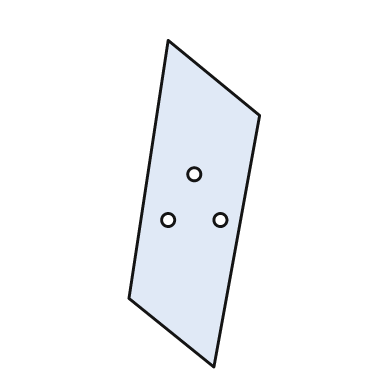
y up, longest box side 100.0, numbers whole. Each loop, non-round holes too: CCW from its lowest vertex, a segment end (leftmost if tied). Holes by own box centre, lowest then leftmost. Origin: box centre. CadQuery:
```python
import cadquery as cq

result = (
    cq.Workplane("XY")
    .moveTo(6.0, -50.0)
    .lineTo(20.0, 27.0)
    .lineTo(-8.0, 50.0)
    .lineTo(-20.0, -29.0)
    .close()
    .moveTo(-8.0, -5.0)
    .circle(2.0)
    .moveTo(8.0, -5.0)
    .circle(2.0)
    .moveTo(0.0, 9.0)
    .circle(2.0)
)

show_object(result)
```